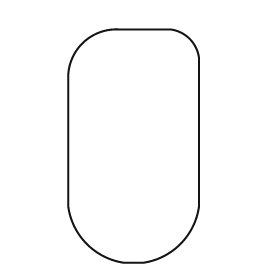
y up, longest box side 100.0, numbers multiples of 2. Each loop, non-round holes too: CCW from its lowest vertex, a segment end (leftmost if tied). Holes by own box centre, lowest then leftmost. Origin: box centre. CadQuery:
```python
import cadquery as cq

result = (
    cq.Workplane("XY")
    .moveTo(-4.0, -50.0)
    .lineTo(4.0, -50.0)
    .threePointArc((20.0, -42.0), (28.0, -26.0))
    .lineTo(28.0, 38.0)
    .threePointArc((24.0, 46.0), (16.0, 50.0))
    .lineTo(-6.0, 50.0)
    .threePointArc((-22.0, 44.0), (-28.0, 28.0))
    .lineTo(-28.0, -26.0)
    .threePointArc((-20.0, -42.0), (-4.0, -50.0))
    .close()
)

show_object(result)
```